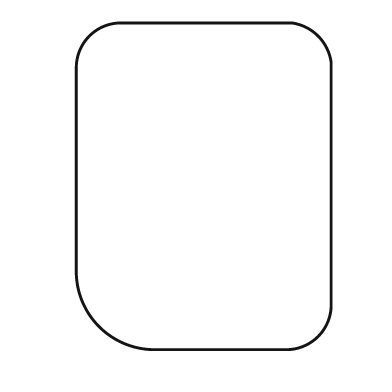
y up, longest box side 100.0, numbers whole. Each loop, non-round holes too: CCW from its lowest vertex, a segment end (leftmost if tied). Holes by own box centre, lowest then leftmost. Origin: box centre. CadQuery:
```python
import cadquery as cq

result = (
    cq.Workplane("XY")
    .moveTo(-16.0, -50.0)
    .lineTo(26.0, -50.0)
    .threePointArc((35.0, -46.0), (39.0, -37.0))
    .lineTo(39.0, 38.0)
    .threePointArc((35.0, 46.0), (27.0, 50.0))
    .lineTo(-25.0, 50.0)
    .threePointArc((-35.0, 46.0), (-39.0, 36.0))
    .lineTo(-39.0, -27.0)
    .threePointArc((-32.0, -43.0), (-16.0, -50.0))
    .close()
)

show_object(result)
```